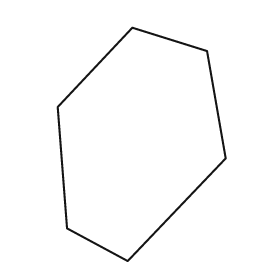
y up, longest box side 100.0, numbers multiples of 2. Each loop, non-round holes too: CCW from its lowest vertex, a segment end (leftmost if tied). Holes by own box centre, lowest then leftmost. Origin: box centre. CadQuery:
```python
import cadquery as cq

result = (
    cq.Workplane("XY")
    .moveTo(-6.0, -50.0)
    .lineTo(36.0, -6.0)
    .lineTo(28.0, 40.0)
    .lineTo(-4.0, 50.0)
    .lineTo(-36.0, 16.0)
    .lineTo(-32.0, -36.0)
    .close()
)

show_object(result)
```